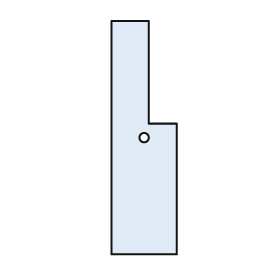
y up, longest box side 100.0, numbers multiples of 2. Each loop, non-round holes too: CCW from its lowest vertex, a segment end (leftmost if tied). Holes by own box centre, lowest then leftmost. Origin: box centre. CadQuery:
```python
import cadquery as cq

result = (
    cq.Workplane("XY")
    .moveTo(-14.0, -50.0)
    .lineTo(14.0, -50.0)
    .lineTo(14.0, 6.0)
    .lineTo(2.0, 6.0)
    .lineTo(2.0, 50.0)
    .lineTo(-14.0, 50.0)
    .close()
    .moveTo(0.0, 0.0)
    .circle(2.0)
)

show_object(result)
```